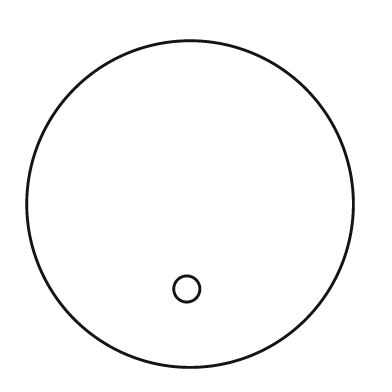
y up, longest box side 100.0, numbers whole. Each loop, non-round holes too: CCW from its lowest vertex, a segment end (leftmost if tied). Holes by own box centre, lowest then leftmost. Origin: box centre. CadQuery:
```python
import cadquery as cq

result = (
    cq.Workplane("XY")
    .moveTo(0.0, 0.0)
    .circle(50.0)
    .moveTo(-1.0, -26.0)
    .circle(4.0)
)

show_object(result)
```